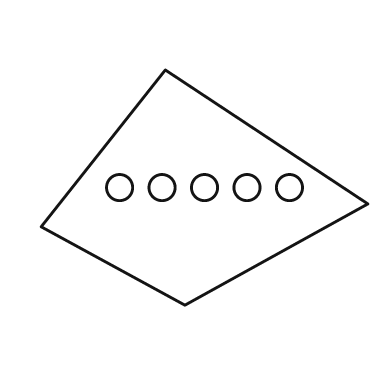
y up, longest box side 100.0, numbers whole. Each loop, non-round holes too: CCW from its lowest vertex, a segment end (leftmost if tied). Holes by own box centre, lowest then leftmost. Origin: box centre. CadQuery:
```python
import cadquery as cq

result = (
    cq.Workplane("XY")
    .moveTo(-6.0, -36.0)
    .lineTo(50.0, -5.0)
    .lineTo(-12.0, 36.0)
    .lineTo(-50.0, -12.0)
    .close()
    .moveTo(-26.0, 0.0)
    .circle(4.0)
    .moveTo(-13.0, 0.0)
    .circle(4.0)
    .moveTo(0.0, 0.0)
    .circle(4.0)
    .moveTo(13.0, 0.0)
    .circle(4.0)
    .moveTo(26.0, 0.0)
    .circle(4.0)
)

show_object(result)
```